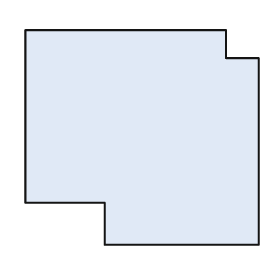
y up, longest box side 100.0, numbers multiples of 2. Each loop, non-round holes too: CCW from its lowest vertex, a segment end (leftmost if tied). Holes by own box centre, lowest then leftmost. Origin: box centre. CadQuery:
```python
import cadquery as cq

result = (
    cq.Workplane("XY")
    .moveTo(-16.0, -46.0)
    .lineTo(50.0, -46.0)
    .lineTo(50.0, 34.0)
    .lineTo(36.0, 34.0)
    .lineTo(36.0, 46.0)
    .lineTo(-50.0, 46.0)
    .lineTo(-50.0, -28.0)
    .lineTo(-16.0, -28.0)
    .close()
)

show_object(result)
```